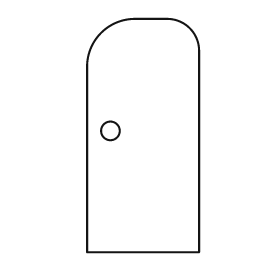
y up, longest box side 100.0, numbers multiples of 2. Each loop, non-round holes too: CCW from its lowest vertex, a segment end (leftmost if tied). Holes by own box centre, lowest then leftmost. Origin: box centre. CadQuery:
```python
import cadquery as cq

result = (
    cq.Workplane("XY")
    .moveTo(-24.0, -50.0)
    .lineTo(24.0, -50.0)
    .lineTo(24.0, 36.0)
    .threePointArc((20.0, 46.0), (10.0, 50.0))
    .lineTo(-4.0, 50.0)
    .threePointArc((-18.0, 44.0), (-24.0, 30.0))
    .close()
    .moveTo(-14.0, 2.0)
    .circle(4.0)
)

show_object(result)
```